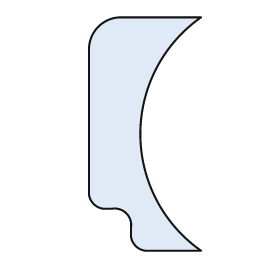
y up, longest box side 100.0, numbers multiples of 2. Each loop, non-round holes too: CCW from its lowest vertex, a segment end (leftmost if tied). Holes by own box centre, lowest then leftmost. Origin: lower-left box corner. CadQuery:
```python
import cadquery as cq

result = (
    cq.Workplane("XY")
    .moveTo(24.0, 0.0)
    .lineTo(48.0, 0.0)
    .threePointArc((22.0, 50.0), (48.0, 100.0))
    .lineTo(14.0, 100.0)
    .threePointArc((4.0, 96.0), (0.0, 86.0))
    .lineTo(0.0, 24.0)
    .threePointArc((2.0, 20.0), (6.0, 18.0))
    .lineTo(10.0, 18.0)
    .threePointArc((16.0, 16.0), (18.0, 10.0))
    .lineTo(18.0, 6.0)
    .threePointArc((20.0, 2.0), (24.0, 0.0))
    .close()
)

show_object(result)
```